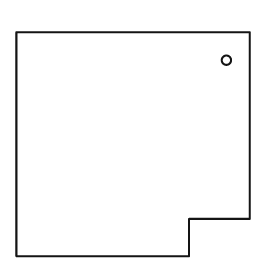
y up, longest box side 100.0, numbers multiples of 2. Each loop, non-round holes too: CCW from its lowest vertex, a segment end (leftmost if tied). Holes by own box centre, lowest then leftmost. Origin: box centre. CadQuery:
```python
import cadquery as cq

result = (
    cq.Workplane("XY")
    .moveTo(-50.0, -48.0)
    .lineTo(24.0, -48.0)
    .lineTo(24.0, -32.0)
    .lineTo(50.0, -32.0)
    .lineTo(50.0, 48.0)
    .lineTo(-50.0, 48.0)
    .close()
    .moveTo(40.0, 36.0)
    .circle(2.0)
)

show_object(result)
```